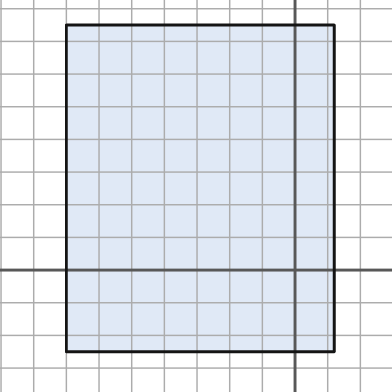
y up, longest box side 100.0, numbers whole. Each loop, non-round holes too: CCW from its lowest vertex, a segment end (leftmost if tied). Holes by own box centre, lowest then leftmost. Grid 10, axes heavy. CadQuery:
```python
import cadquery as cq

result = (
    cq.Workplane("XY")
    .moveTo(-70.0, -25.0)
    .lineTo(12.0, -25.0)
    .lineTo(12.0, 75.0)
    .lineTo(-70.0, 75.0)
    .close()
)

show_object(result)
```